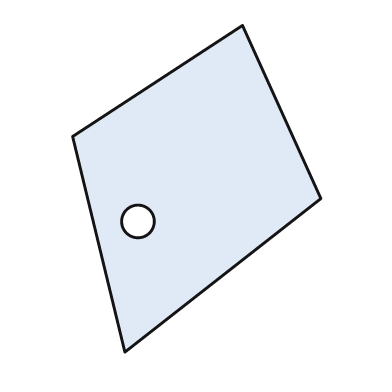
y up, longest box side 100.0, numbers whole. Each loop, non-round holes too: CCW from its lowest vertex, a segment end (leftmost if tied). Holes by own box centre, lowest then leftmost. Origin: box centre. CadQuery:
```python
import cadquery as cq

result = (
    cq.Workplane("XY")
    .moveTo(-22.0, -50.0)
    .lineTo(38.0, -3.0)
    .lineTo(14.0, 50.0)
    .lineTo(-38.0, 16.0)
    .close()
    .moveTo(-18.0, -10.0)
    .circle(5.0)
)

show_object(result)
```